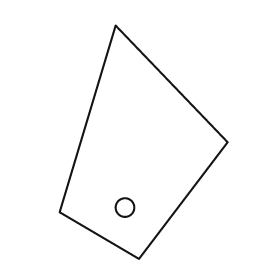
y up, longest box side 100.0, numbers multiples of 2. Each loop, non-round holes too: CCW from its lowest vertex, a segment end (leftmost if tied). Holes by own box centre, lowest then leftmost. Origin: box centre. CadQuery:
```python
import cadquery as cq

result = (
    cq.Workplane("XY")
    .moveTo(-2.0, -50.0)
    .lineTo(36.0, 0.0)
    .lineTo(-12.0, 50.0)
    .lineTo(-36.0, -30.0)
    .close()
    .moveTo(-8.0, -28.0)
    .circle(4.0)
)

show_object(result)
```